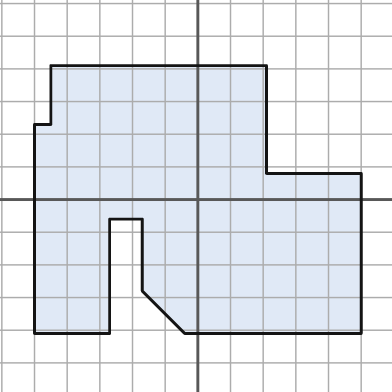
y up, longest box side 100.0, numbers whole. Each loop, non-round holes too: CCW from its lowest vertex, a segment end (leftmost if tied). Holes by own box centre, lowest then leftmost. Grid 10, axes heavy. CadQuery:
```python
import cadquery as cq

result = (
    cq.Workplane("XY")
    .moveTo(-50.0, -41.0)
    .lineTo(-27.0, -41.0)
    .lineTo(-27.0, -6.0)
    .lineTo(-17.0, -6.0)
    .lineTo(-17.0, -28.0)
    .lineTo(-4.0, -41.0)
    .lineTo(50.0, -41.0)
    .lineTo(50.0, 8.0)
    .lineTo(21.0, 8.0)
    .lineTo(21.0, 41.0)
    .lineTo(-45.0, 41.0)
    .lineTo(-45.0, 23.0)
    .lineTo(-50.0, 23.0)
    .close()
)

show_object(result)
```